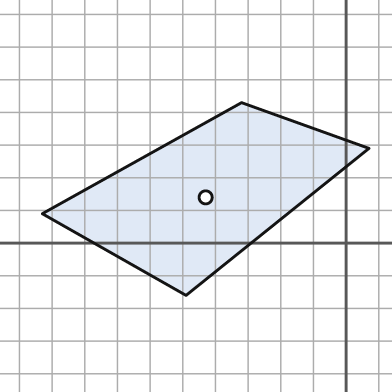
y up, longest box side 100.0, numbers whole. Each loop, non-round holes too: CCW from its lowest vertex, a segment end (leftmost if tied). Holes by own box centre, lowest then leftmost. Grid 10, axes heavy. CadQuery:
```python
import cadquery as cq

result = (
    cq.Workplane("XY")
    .moveTo(-49.0, -16.0)
    .lineTo(7.0, 29.0)
    .lineTo(-32.0, 43.0)
    .lineTo(-93.0, 9.0)
    .close()
    .moveTo(-43.0, 14.0)
    .circle(2.0)
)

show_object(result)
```